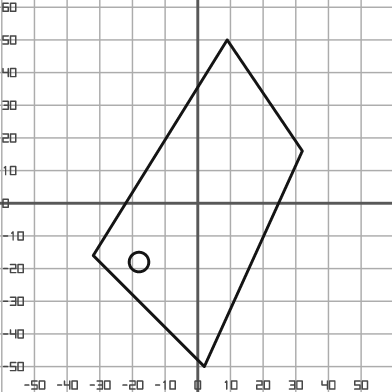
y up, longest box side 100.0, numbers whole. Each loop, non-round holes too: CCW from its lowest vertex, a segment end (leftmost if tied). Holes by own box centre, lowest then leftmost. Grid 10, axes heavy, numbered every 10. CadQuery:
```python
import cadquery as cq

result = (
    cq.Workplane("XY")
    .moveTo(2.0, -50.0)
    .lineTo(32.0, 16.0)
    .lineTo(9.0, 50.0)
    .lineTo(-32.0, -16.0)
    .close()
    .moveTo(-18.0, -18.0)
    .circle(3.0)
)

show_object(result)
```